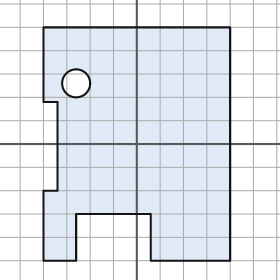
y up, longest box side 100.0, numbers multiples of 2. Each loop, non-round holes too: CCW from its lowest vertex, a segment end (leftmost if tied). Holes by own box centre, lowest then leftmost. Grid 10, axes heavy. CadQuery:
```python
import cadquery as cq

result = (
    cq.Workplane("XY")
    .moveTo(-40.0, -50.0)
    .lineTo(-26.0, -50.0)
    .lineTo(-26.0, -30.0)
    .lineTo(6.0, -30.0)
    .lineTo(6.0, -50.0)
    .lineTo(40.0, -50.0)
    .lineTo(40.0, 50.0)
    .lineTo(-40.0, 50.0)
    .lineTo(-40.0, 18.0)
    .lineTo(-34.0, 18.0)
    .lineTo(-34.0, -20.0)
    .lineTo(-40.0, -20.0)
    .close()
    .moveTo(-26.0, 26.0)
    .circle(6.0)
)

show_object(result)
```